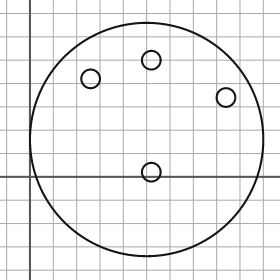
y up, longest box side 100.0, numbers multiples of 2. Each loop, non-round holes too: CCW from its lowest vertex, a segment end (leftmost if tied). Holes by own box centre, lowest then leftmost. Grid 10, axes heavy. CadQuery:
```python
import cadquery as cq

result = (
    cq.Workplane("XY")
    .moveTo(50.0, 16.0)
    .circle(50.0)
    .moveTo(52.0, 2.0)
    .circle(4.0)
    .moveTo(84.0, 34.0)
    .circle(4.0)
    .moveTo(26.0, 42.0)
    .circle(4.0)
    .moveTo(52.0, 50.0)
    .circle(4.0)
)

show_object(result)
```